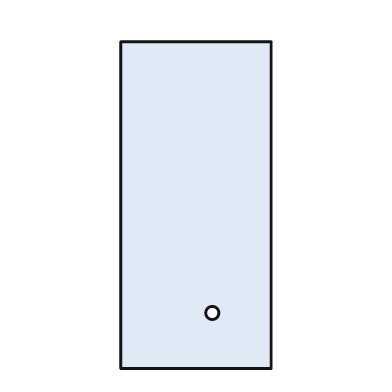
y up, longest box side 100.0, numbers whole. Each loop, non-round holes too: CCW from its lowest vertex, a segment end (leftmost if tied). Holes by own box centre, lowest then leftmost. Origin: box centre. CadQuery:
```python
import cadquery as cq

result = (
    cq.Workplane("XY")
    .moveTo(-23.0, -50.0)
    .lineTo(23.0, -50.0)
    .lineTo(23.0, 50.0)
    .lineTo(-23.0, 50.0)
    .close()
    .moveTo(5.0, -33.0)
    .circle(2.0)
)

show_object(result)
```